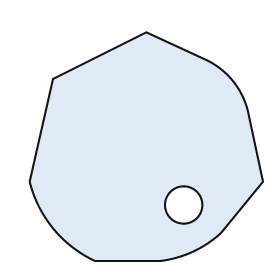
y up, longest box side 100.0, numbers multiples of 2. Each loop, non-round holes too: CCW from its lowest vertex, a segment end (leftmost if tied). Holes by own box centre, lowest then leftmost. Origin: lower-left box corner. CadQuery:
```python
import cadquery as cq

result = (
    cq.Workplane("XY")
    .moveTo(28.0, 0.0)
    .lineTo(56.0, 0.0)
    .threePointArc((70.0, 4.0), (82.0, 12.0))
    .lineTo(100.0, 34.0)
    .lineTo(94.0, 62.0)
    .threePointArc((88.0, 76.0), (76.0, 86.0))
    .lineTo(50.0, 98.0)
    .lineTo(10.0, 78.0)
    .lineTo(0.0, 34.0)
    .threePointArc((10.0, 14.0), (28.0, 0.0))
    .close()
    .moveTo(66.0, 24.0)
    .circle(8.0)
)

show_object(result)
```